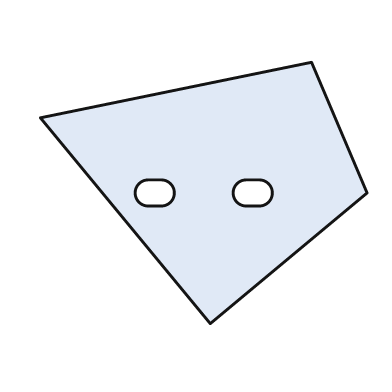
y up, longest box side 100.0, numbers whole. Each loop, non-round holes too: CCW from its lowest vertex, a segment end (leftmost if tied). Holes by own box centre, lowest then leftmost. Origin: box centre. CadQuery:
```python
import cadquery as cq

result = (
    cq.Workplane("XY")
    .moveTo(2.0, -40.0)
    .lineTo(50.0, 0.0)
    .lineTo(33.0, 40.0)
    .lineTo(-50.0, 23.0)
    .close()
    .moveTo(-17.0, -4.0)
    .lineTo(-13.0, -4.0)
    .threePointArc((-9.0, 0.0), (-13.0, 4.0))
    .lineTo(-17.0, 4.0)
    .threePointArc((-21.0, 0.0), (-17.0, -4.0))
    .close()
    .moveTo(13.0, -4.0)
    .lineTo(17.0, -4.0)
    .threePointArc((21.0, 0.0), (17.0, 4.0))
    .lineTo(13.0, 4.0)
    .threePointArc((9.0, 0.0), (13.0, -4.0))
    .close()
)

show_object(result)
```